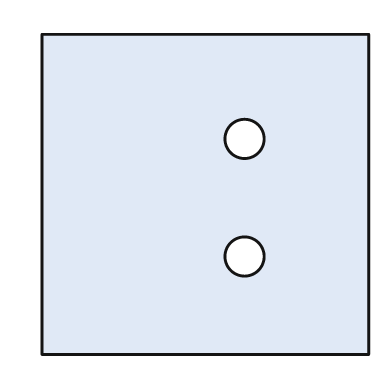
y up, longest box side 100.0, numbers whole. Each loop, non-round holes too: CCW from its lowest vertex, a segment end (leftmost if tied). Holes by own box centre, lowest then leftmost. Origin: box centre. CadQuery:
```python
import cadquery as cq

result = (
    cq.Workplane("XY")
    .moveTo(-50.0, -49.0)
    .lineTo(50.0, -49.0)
    .lineTo(50.0, 49.0)
    .lineTo(-50.0, 49.0)
    .close()
    .moveTo(12.0, -19.0)
    .circle(6.0)
    .moveTo(12.0, 17.0)
    .circle(6.0)
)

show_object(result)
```